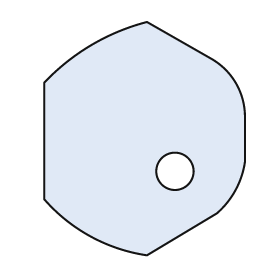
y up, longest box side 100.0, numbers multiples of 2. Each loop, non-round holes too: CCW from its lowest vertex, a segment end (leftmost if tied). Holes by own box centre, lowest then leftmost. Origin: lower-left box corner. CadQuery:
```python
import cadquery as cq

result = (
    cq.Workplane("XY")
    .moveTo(44.0, 0.0)
    .lineTo(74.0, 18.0)
    .threePointArc((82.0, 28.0), (86.0, 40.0))
    .lineTo(86.0, 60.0)
    .threePointArc((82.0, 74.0), (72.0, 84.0))
    .lineTo(44.0, 100.0)
    .threePointArc((20.0, 90.0), (0.0, 74.0))
    .lineTo(0.0, 24.0)
    .threePointArc((20.0, 8.0), (44.0, 0.0))
    .close()
    .moveTo(56.0, 36.0)
    .circle(8.0)
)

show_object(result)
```